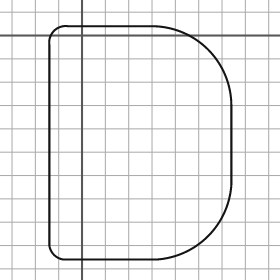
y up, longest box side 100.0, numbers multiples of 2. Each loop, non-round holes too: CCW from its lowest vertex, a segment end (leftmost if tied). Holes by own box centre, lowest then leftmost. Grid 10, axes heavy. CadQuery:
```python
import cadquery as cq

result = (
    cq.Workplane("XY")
    .moveTo(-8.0, -96.0)
    .lineTo(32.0, -96.0)
    .threePointArc((54.0, -86.0), (64.0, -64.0))
    .lineTo(64.0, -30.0)
    .threePointArc((54.0, -6.0), (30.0, 4.0))
    .lineTo(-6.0, 4.0)
    .threePointArc((-12.0, 2.0), (-14.0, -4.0))
    .lineTo(-14.0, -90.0)
    .threePointArc((-12.0, -94.0), (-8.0, -96.0))
    .close()
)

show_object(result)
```